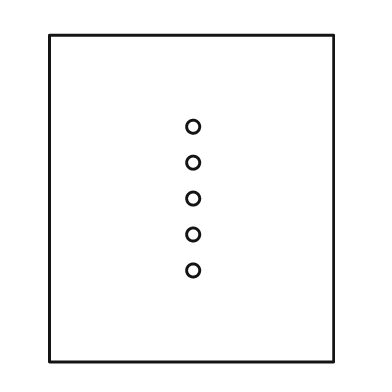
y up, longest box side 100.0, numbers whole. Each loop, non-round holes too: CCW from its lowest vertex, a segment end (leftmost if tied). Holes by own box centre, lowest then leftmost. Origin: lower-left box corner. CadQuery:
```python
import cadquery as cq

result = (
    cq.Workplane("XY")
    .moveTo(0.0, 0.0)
    .lineTo(87.0, 0.0)
    .lineTo(87.0, 100.0)
    .lineTo(0.0, 100.0)
    .close()
    .moveTo(44.0, 28.0)
    .circle(2.0)
    .moveTo(44.0, 39.0)
    .circle(2.0)
    .moveTo(44.0, 50.0)
    .circle(2.0)
    .moveTo(44.0, 61.0)
    .circle(2.0)
    .moveTo(44.0, 72.0)
    .circle(2.0)
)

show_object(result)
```